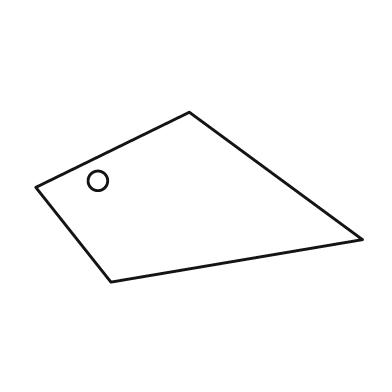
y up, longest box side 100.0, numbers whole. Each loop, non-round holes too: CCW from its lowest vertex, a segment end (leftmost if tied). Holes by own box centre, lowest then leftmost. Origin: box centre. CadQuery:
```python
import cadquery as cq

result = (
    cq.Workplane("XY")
    .moveTo(-27.0, -26.0)
    .lineTo(50.0, -13.0)
    .lineTo(-3.0, 26.0)
    .lineTo(-50.0, 3.0)
    .close()
    .moveTo(-31.0, 5.0)
    .circle(3.0)
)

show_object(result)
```